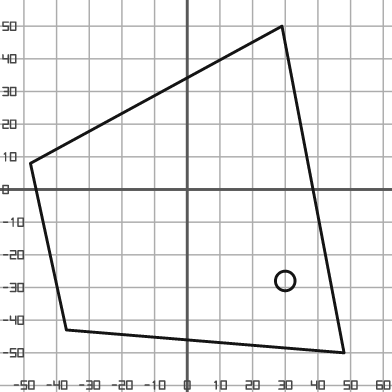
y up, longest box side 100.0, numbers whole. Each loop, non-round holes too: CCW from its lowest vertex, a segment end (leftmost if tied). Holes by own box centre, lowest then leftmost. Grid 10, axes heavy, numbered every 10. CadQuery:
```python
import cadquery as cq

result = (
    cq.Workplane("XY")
    .moveTo(48.0, -50.0)
    .lineTo(29.0, 50.0)
    .lineTo(-48.0, 8.0)
    .lineTo(-37.0, -43.0)
    .close()
    .moveTo(30.0, -28.0)
    .circle(3.0)
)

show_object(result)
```